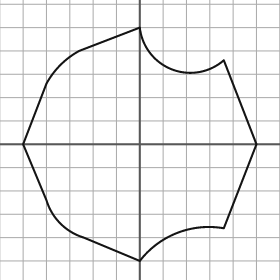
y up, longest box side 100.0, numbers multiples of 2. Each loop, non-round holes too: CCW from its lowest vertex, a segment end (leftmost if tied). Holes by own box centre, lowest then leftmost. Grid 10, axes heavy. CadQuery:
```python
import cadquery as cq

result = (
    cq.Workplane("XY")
    .moveTo(0.0, -50.0)
    .threePointArc((16.0, -38.0), (36.0, -36.0))
    .lineTo(50.0, 0.0)
    .lineTo(36.0, 36.0)
    .threePointArc((14.0, 32.0), (0.0, 50.0))
    .lineTo(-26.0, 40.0)
    .threePointArc((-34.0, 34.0), (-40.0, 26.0))
    .lineTo(-50.0, 0.0)
    .lineTo(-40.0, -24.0)
    .threePointArc((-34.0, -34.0), (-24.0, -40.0))
    .close()
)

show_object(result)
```